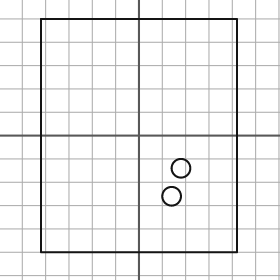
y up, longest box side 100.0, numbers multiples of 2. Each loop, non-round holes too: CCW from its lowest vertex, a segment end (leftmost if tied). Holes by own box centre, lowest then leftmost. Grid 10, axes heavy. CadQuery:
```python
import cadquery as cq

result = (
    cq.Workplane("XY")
    .moveTo(-42.0, -50.0)
    .lineTo(42.0, -50.0)
    .lineTo(42.0, 50.0)
    .lineTo(-42.0, 50.0)
    .close()
    .moveTo(14.0, -26.0)
    .circle(4.0)
    .moveTo(18.0, -14.0)
    .circle(4.0)
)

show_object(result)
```